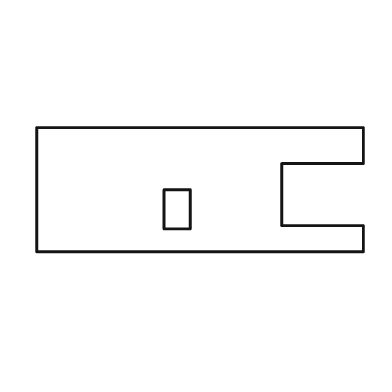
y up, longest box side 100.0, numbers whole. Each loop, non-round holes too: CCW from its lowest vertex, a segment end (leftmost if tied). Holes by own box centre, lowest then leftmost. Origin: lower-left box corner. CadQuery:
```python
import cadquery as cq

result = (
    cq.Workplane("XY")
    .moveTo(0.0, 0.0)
    .lineTo(100.0, 0.0)
    .lineTo(100.0, 8.0)
    .lineTo(75.0, 8.0)
    .lineTo(75.0, 27.0)
    .lineTo(100.0, 27.0)
    .lineTo(100.0, 38.0)
    .lineTo(0.0, 38.0)
    .close()
    .moveTo(39.0, 7.0)
    .lineTo(47.0, 7.0)
    .lineTo(47.0, 19.0)
    .lineTo(39.0, 19.0)
    .close()
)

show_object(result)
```